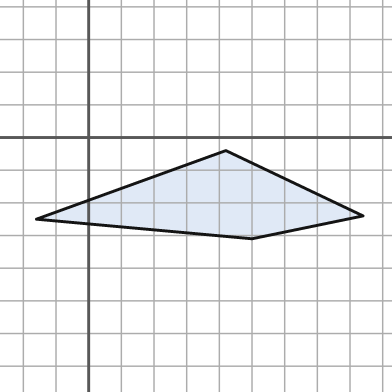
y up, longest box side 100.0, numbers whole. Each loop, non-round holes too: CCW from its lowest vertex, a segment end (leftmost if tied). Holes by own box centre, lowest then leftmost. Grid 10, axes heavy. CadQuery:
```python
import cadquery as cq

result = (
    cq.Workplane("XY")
    .moveTo(50.0, -31.0)
    .lineTo(84.0, -24.0)
    .lineTo(42.0, -4.0)
    .lineTo(-16.0, -25.0)
    .close()
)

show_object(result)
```